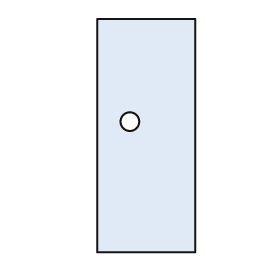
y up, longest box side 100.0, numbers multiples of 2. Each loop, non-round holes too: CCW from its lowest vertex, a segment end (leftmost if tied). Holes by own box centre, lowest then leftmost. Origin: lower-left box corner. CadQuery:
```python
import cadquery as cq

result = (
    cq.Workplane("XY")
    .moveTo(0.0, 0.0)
    .lineTo(42.0, 0.0)
    .lineTo(42.0, 100.0)
    .lineTo(0.0, 100.0)
    .close()
    .moveTo(14.0, 56.0)
    .circle(4.0)
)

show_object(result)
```